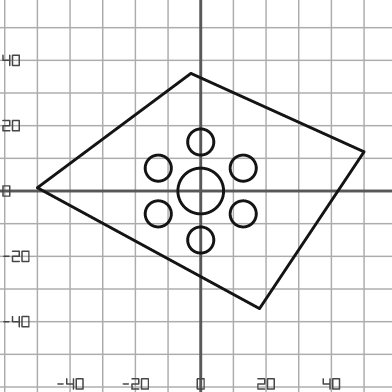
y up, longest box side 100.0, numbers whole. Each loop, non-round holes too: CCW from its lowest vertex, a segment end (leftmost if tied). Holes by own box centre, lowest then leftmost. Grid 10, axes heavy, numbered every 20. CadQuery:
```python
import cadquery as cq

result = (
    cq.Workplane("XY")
    .moveTo(18.0, -36.0)
    .lineTo(50.0, 12.0)
    .lineTo(-3.0, 36.0)
    .lineTo(-50.0, 1.0)
    .close()
    .moveTo(0.0, -15.0)
    .circle(4.0)
    .moveTo(-13.0, -7.0)
    .circle(4.0)
    .moveTo(13.0, -7.0)
    .circle(4.0)
    .moveTo(0.0, 0.0)
    .circle(7.0)
    .moveTo(-13.0, 7.0)
    .circle(4.0)
    .moveTo(13.0, 7.0)
    .circle(4.0)
    .moveTo(0.0, 15.0)
    .circle(4.0)
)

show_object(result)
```